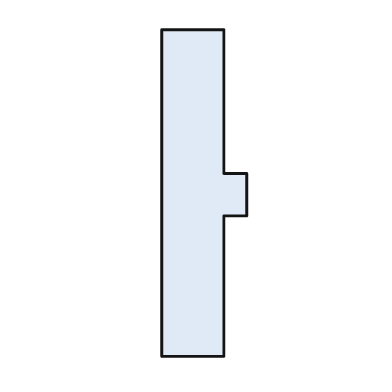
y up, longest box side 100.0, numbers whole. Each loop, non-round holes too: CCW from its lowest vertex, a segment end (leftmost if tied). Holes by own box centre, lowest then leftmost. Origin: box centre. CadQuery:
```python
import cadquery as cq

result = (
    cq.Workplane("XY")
    .moveTo(-13.0, -50.0)
    .lineTo(6.0, -50.0)
    .lineTo(6.0, -7.0)
    .lineTo(13.0, -7.0)
    .lineTo(13.0, 6.0)
    .lineTo(6.0, 6.0)
    .lineTo(6.0, 50.0)
    .lineTo(-13.0, 50.0)
    .close()
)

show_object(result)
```